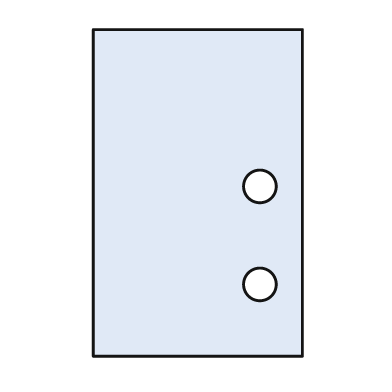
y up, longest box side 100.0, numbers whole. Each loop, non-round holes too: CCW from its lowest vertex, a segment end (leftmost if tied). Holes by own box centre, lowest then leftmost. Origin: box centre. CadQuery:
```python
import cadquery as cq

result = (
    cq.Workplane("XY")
    .moveTo(-32.0, -50.0)
    .lineTo(32.0, -50.0)
    .lineTo(32.0, 50.0)
    .lineTo(-32.0, 50.0)
    .close()
    .moveTo(19.0, -28.0)
    .circle(5.0)
    .moveTo(19.0, 2.0)
    .circle(5.0)
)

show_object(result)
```